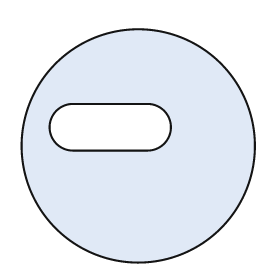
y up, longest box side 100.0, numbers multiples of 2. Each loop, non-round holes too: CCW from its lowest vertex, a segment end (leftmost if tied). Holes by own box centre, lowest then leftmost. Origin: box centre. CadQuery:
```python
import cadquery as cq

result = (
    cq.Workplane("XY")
    .moveTo(0.0, 0.0)
    .circle(50.0)
    .moveTo(-28.0, -2.0)
    .lineTo(4.0, -2.0)
    .threePointArc((14.0, 8.0), (4.0, 18.0))
    .lineTo(-28.0, 18.0)
    .threePointArc((-38.0, 8.0), (-28.0, -2.0))
    .close()
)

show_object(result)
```